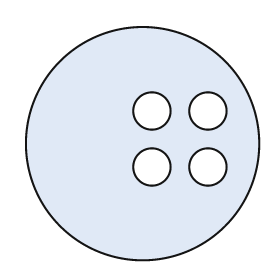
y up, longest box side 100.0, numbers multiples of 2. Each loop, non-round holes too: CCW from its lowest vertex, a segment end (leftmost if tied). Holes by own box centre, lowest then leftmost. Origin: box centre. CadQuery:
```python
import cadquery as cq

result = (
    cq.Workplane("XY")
    .moveTo(0.0, 0.0)
    .circle(50.0)
    .moveTo(4.0, -10.0)
    .circle(8.0)
    .moveTo(28.0, -10.0)
    .circle(8.0)
    .moveTo(4.0, 14.0)
    .circle(8.0)
    .moveTo(28.0, 14.0)
    .circle(8.0)
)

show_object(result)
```